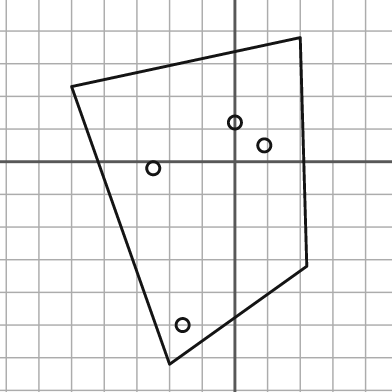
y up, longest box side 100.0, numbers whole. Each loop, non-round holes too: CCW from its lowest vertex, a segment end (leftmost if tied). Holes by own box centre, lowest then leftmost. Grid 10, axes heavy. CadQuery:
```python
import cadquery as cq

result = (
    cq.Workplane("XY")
    .moveTo(-20.0, -62.0)
    .lineTo(22.0, -32.0)
    .lineTo(20.0, 38.0)
    .lineTo(-50.0, 23.0)
    .close()
    .moveTo(-16.0, -50.0)
    .circle(2.0)
    .moveTo(-25.0, -2.0)
    .circle(2.0)
    .moveTo(9.0, 5.0)
    .circle(2.0)
    .moveTo(0.0, 12.0)
    .circle(2.0)
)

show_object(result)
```